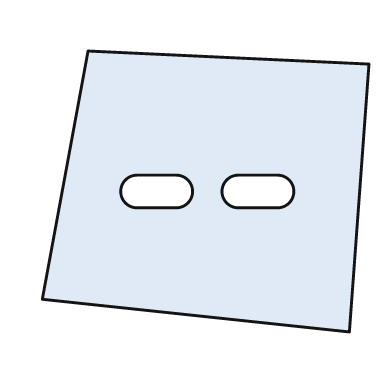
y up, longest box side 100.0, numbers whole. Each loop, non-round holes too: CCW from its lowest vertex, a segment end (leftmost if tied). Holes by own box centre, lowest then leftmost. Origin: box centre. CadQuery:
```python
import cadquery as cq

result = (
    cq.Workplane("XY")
    .moveTo(44.0, -43.0)
    .lineTo(50.0, 39.0)
    .lineTo(-36.0, 43.0)
    .lineTo(-50.0, -33.0)
    .close()
    .moveTo(-21.0, -5.0)
    .lineTo(-9.0, -5.0)
    .threePointArc((-4.0, 0.0), (-9.0, 5.0))
    .lineTo(-21.0, 5.0)
    .threePointArc((-26.0, 0.0), (-21.0, -5.0))
    .close()
    .moveTo(10.0, -5.0)
    .lineTo(22.0, -5.0)
    .threePointArc((27.0, 0.0), (22.0, 5.0))
    .lineTo(10.0, 5.0)
    .threePointArc((5.0, 0.0), (10.0, -5.0))
    .close()
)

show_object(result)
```